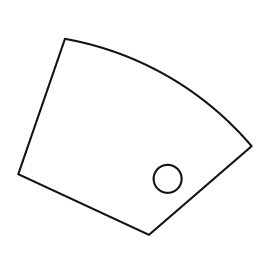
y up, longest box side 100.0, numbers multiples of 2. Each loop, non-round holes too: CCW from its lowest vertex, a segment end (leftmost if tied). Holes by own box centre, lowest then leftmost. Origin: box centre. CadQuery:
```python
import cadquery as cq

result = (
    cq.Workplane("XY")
    .moveTo(6.0, -42.0)
    .lineTo(50.0, -4.0)
    .threePointArc((14.0, 26.0), (-30.0, 42.0))
    .lineTo(-50.0, -16.0)
    .close()
    .moveTo(14.0, -18.0)
    .circle(6.0)
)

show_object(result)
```